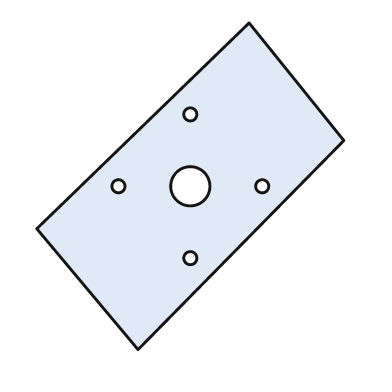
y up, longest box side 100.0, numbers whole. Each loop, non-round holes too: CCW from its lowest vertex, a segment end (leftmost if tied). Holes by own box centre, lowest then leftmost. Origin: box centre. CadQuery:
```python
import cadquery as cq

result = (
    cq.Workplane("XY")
    .moveTo(-16.0, -50.0)
    .lineTo(47.0, 14.0)
    .lineTo(18.0, 50.0)
    .lineTo(-47.0, -13.0)
    .close()
    .moveTo(0.0, -22.0)
    .circle(2.0)
    .moveTo(-22.0, 0.0)
    .circle(2.0)
    .moveTo(0.0, 0.0)
    .circle(6.0)
    .moveTo(22.0, 0.0)
    .circle(2.0)
    .moveTo(0.0, 22.0)
    .circle(2.0)
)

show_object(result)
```